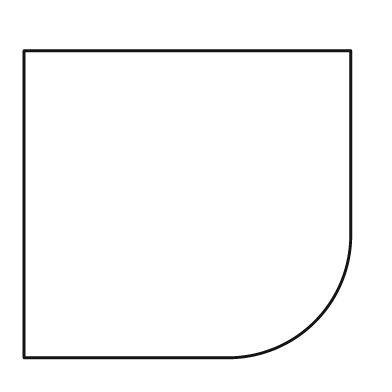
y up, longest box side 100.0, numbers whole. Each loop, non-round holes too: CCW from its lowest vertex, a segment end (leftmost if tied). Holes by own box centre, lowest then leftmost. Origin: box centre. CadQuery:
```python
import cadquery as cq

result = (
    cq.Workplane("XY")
    .moveTo(-50.0, -47.0)
    .lineTo(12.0, -47.0)
    .threePointArc((39.0, -36.0), (50.0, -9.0))
    .lineTo(50.0, 47.0)
    .lineTo(-50.0, 47.0)
    .close()
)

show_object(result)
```